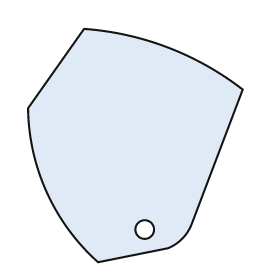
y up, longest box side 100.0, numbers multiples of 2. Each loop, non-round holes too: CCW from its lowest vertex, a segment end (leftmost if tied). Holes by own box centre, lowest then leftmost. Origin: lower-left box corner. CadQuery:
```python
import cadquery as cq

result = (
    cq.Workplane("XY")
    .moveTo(30.0, 0.0)
    .lineTo(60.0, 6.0)
    .threePointArc((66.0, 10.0), (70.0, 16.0))
    .lineTo(92.0, 74.0)
    .threePointArc((60.0, 92.0), (24.0, 100.0))
    .lineTo(0.0, 66.0)
    .threePointArc((8.0, 30.0), (30.0, 0.0))
    .close()
    .moveTo(50.0, 14.0)
    .circle(4.0)
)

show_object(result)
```